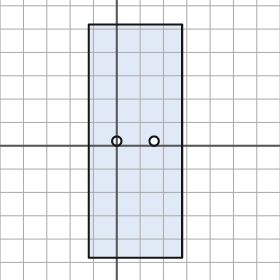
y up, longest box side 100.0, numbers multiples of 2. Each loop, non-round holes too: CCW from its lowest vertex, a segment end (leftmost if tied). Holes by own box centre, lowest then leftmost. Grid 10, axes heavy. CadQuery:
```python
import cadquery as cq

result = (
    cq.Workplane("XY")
    .moveTo(-12.0, -48.0)
    .lineTo(28.0, -48.0)
    .lineTo(28.0, 52.0)
    .lineTo(-12.0, 52.0)
    .close()
    .moveTo(0.0, 2.0)
    .circle(2.0)
    .moveTo(16.0, 2.0)
    .circle(2.0)
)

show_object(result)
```